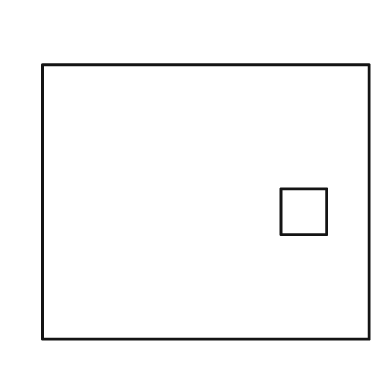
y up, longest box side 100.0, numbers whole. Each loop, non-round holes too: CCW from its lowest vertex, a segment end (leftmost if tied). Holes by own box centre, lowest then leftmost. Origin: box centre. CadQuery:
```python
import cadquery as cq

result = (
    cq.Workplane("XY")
    .moveTo(-50.0, -42.0)
    .lineTo(50.0, -42.0)
    .lineTo(50.0, 42.0)
    .lineTo(-50.0, 42.0)
    .close()
    .moveTo(23.0, -10.0)
    .lineTo(37.0, -10.0)
    .lineTo(37.0, 4.0)
    .lineTo(23.0, 4.0)
    .close()
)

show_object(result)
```